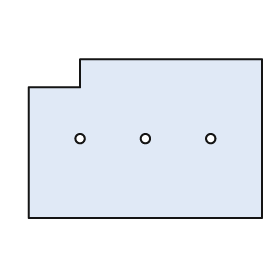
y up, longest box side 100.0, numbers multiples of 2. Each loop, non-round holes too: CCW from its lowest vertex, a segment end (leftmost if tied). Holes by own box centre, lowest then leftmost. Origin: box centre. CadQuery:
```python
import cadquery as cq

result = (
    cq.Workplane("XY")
    .moveTo(-50.0, -34.0)
    .lineTo(50.0, -34.0)
    .lineTo(50.0, 34.0)
    .lineTo(-28.0, 34.0)
    .lineTo(-28.0, 22.0)
    .lineTo(-50.0, 22.0)
    .close()
    .moveTo(-28.0, 0.0)
    .circle(2.0)
    .moveTo(0.0, 0.0)
    .circle(2.0)
    .moveTo(28.0, 0.0)
    .circle(2.0)
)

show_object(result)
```